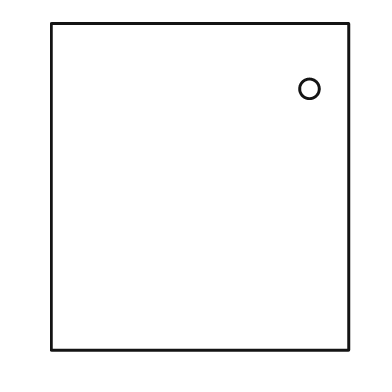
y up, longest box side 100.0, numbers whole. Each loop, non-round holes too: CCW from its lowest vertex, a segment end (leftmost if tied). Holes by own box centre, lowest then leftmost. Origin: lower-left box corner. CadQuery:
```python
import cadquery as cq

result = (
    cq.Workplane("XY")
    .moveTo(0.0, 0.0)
    .lineTo(91.0, 0.0)
    .lineTo(91.0, 100.0)
    .lineTo(0.0, 100.0)
    .close()
    .moveTo(79.0, 80.0)
    .circle(3.0)
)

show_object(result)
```